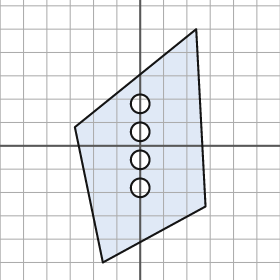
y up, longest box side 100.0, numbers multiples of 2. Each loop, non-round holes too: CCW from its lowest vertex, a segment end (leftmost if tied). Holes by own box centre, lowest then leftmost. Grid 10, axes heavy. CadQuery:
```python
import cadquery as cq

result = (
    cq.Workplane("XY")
    .moveTo(-16.0, -50.0)
    .lineTo(28.0, -26.0)
    .lineTo(24.0, 50.0)
    .lineTo(-28.0, 8.0)
    .close()
    .moveTo(0.0, -18.0)
    .circle(4.0)
    .moveTo(0.0, -6.0)
    .circle(4.0)
    .moveTo(0.0, 6.0)
    .circle(4.0)
    .moveTo(0.0, 18.0)
    .circle(4.0)
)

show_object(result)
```